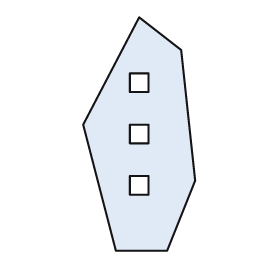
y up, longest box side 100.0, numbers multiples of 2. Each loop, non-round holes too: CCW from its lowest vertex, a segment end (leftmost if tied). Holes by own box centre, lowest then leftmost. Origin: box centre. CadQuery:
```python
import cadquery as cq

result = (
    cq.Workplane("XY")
    .moveTo(-10.0, -50.0)
    .lineTo(12.0, -50.0)
    .lineTo(24.0, -20.0)
    .lineTo(18.0, 36.0)
    .lineTo(0.0, 50.0)
    .lineTo(-24.0, 4.0)
    .close()
    .moveTo(-4.0, -26.0)
    .lineTo(4.0, -26.0)
    .lineTo(4.0, -18.0)
    .lineTo(-4.0, -18.0)
    .close()
    .moveTo(-4.0, -4.0)
    .lineTo(4.0, -4.0)
    .lineTo(4.0, 4.0)
    .lineTo(-4.0, 4.0)
    .close()
    .moveTo(-4.0, 18.0)
    .lineTo(4.0, 18.0)
    .lineTo(4.0, 26.0)
    .lineTo(-4.0, 26.0)
    .close()
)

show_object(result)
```